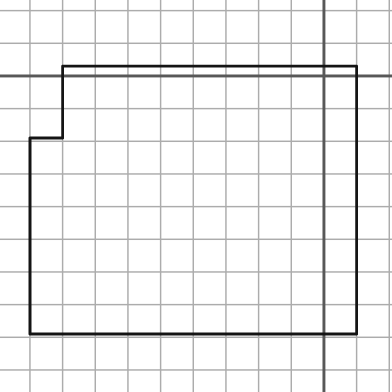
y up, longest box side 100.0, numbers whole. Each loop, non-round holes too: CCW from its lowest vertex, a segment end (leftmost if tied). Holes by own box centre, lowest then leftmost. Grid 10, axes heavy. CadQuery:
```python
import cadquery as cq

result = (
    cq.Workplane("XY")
    .moveTo(-90.0, -79.0)
    .lineTo(10.0, -79.0)
    .lineTo(10.0, 3.0)
    .lineTo(-80.0, 3.0)
    .lineTo(-80.0, -19.0)
    .lineTo(-90.0, -19.0)
    .close()
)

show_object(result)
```